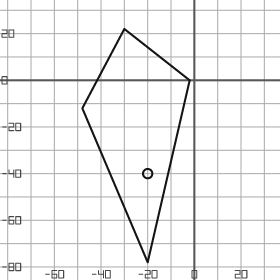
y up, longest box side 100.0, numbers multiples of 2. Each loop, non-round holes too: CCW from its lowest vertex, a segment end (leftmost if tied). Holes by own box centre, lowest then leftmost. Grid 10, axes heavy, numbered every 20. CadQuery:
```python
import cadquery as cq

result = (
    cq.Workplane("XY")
    .moveTo(-20.0, -78.0)
    .lineTo(-2.0, 0.0)
    .lineTo(-30.0, 22.0)
    .lineTo(-48.0, -12.0)
    .close()
    .moveTo(-20.0, -40.0)
    .circle(2.0)
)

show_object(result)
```